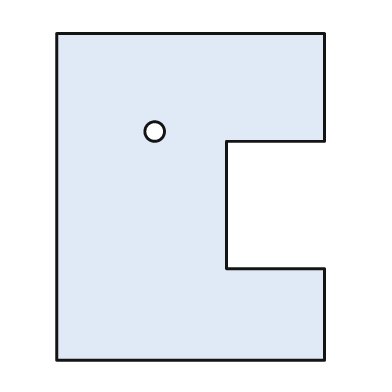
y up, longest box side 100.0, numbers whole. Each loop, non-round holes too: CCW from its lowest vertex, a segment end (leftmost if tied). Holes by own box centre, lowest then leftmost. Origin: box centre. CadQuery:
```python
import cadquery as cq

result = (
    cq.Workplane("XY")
    .moveTo(-41.0, -50.0)
    .lineTo(41.0, -50.0)
    .lineTo(41.0, -22.0)
    .lineTo(11.0, -22.0)
    .lineTo(11.0, 17.0)
    .lineTo(41.0, 17.0)
    .lineTo(41.0, 50.0)
    .lineTo(-41.0, 50.0)
    .close()
    .moveTo(-11.0, 20.0)
    .circle(3.0)
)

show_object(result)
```